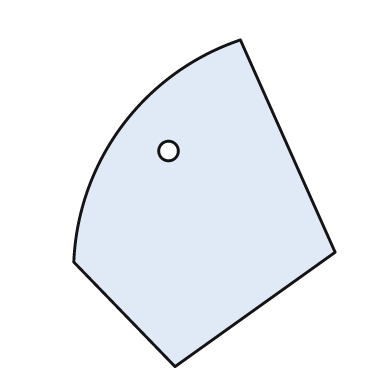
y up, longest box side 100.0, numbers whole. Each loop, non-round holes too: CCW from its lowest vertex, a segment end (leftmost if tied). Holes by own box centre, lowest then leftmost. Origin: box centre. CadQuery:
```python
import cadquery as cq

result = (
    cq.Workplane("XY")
    .moveTo(-9.0, -50.0)
    .lineTo(40.0, -15.0)
    .lineTo(11.0, 50.0)
    .threePointArc((-25.0, 24.0), (-40.0, -18.0))
    .close()
    .moveTo(-11.0, 16.0)
    .circle(3.0)
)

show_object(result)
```